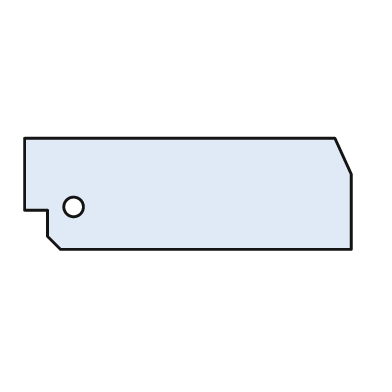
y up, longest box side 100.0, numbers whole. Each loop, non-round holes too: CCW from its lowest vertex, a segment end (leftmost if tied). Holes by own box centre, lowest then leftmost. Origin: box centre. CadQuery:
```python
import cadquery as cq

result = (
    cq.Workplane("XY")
    .moveTo(-39.0, -17.0)
    .lineTo(50.0, -17.0)
    .lineTo(50.0, 6.0)
    .lineTo(45.0, 17.0)
    .lineTo(-50.0, 17.0)
    .lineTo(-50.0, -5.0)
    .lineTo(-43.0, -5.0)
    .lineTo(-43.0, -13.0)
    .close()
    .moveTo(-35.0, -4.0)
    .circle(3.0)
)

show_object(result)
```